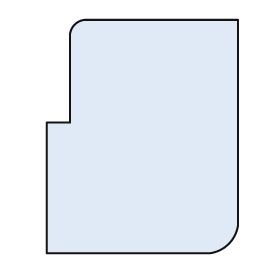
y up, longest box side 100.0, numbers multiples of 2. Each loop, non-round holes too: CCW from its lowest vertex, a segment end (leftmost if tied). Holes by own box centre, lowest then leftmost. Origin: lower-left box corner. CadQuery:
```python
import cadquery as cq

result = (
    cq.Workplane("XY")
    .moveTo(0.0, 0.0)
    .lineTo(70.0, 0.0)
    .threePointArc((78.0, 4.0), (82.0, 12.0))
    .lineTo(82.0, 100.0)
    .lineTo(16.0, 100.0)
    .threePointArc((12.0, 98.0), (10.0, 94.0))
    .lineTo(10.0, 56.0)
    .lineTo(0.0, 56.0)
    .close()
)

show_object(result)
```